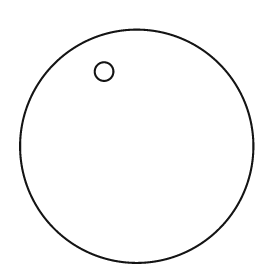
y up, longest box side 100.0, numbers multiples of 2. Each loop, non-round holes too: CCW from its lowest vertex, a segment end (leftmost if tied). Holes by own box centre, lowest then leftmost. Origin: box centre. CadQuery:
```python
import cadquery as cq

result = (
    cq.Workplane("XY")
    .moveTo(0.0, 0.0)
    .circle(50.0)
    .moveTo(-14.0, 32.0)
    .circle(4.0)
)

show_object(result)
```